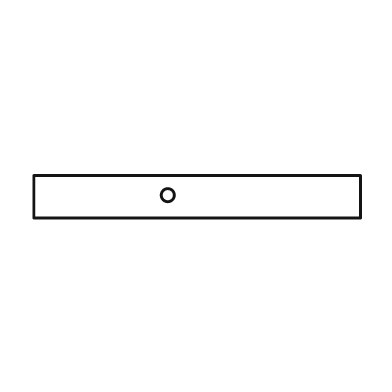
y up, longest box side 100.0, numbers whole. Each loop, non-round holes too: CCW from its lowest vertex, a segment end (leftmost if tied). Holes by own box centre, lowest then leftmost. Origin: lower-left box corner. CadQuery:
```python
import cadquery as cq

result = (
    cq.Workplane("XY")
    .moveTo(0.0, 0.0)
    .lineTo(100.0, 0.0)
    .lineTo(100.0, 13.0)
    .lineTo(0.0, 13.0)
    .close()
    .moveTo(41.0, 7.0)
    .circle(2.0)
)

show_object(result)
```